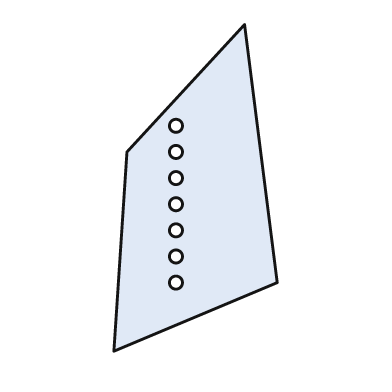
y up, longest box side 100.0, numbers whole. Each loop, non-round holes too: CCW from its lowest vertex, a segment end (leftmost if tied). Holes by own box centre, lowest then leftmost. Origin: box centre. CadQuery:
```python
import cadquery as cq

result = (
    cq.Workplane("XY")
    .moveTo(-25.0, -50.0)
    .lineTo(25.0, -29.0)
    .lineTo(15.0, 50.0)
    .lineTo(-21.0, 11.0)
    .close()
    .moveTo(-6.0, -29.0)
    .circle(2.0)
    .moveTo(-6.0, -21.0)
    .circle(2.0)
    .moveTo(-6.0, -13.0)
    .circle(2.0)
    .moveTo(-6.0, -5.0)
    .circle(2.0)
    .moveTo(-6.0, 3.0)
    .circle(2.0)
    .moveTo(-6.0, 11.0)
    .circle(2.0)
    .moveTo(-6.0, 19.0)
    .circle(2.0)
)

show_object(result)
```